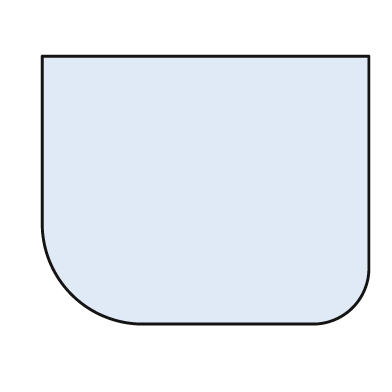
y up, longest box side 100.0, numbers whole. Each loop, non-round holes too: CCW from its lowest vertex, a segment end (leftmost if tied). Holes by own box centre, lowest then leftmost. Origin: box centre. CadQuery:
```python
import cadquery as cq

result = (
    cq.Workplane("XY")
    .moveTo(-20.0, -41.0)
    .lineTo(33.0, -41.0)
    .threePointArc((45.0, -36.0), (50.0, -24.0))
    .lineTo(50.0, 41.0)
    .lineTo(-50.0, 41.0)
    .lineTo(-50.0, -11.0)
    .threePointArc((-41.0, -32.0), (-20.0, -41.0))
    .close()
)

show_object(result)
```